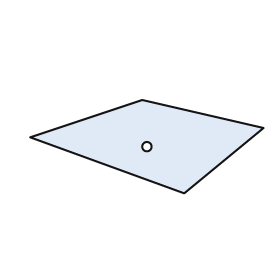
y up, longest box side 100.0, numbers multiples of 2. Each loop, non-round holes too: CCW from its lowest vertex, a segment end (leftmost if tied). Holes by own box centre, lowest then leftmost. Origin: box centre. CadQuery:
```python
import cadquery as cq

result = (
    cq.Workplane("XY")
    .moveTo(16.0, -20.0)
    .lineTo(50.0, 8.0)
    .lineTo(-2.0, 20.0)
    .lineTo(-50.0, 4.0)
    .close()
    .moveTo(0.0, 0.0)
    .circle(2.0)
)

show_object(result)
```